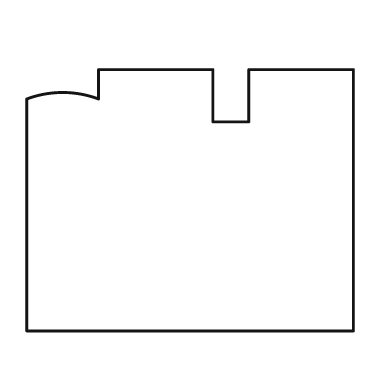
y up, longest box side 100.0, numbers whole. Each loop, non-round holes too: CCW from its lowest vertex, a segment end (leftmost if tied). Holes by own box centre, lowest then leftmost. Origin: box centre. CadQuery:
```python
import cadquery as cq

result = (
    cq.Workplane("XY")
    .moveTo(-50.0, -40.0)
    .lineTo(50.0, -40.0)
    .lineTo(50.0, 40.0)
    .lineTo(18.0, 40.0)
    .lineTo(18.0, 24.0)
    .lineTo(7.0, 24.0)
    .lineTo(7.0, 40.0)
    .lineTo(-28.0, 40.0)
    .lineTo(-28.0, 31.0)
    .threePointArc((-39.0, 33.0), (-50.0, 31.0))
    .close()
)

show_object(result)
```